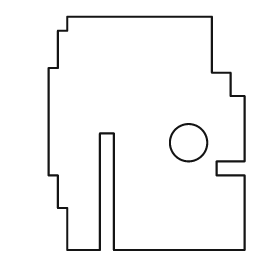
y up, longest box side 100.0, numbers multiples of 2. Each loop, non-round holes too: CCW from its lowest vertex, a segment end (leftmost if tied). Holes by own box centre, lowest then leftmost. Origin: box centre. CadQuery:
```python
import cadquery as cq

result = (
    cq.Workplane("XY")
    .moveTo(-34.0, -50.0)
    .lineTo(-20.0, -50.0)
    .lineTo(-20.0, 0.0)
    .lineTo(-14.0, 0.0)
    .lineTo(-14.0, -50.0)
    .lineTo(42.0, -50.0)
    .lineTo(42.0, -18.0)
    .lineTo(30.0, -18.0)
    .lineTo(30.0, -12.0)
    .lineTo(42.0, -12.0)
    .lineTo(42.0, 16.0)
    .lineTo(36.0, 16.0)
    .lineTo(36.0, 26.0)
    .lineTo(28.0, 26.0)
    .lineTo(28.0, 50.0)
    .lineTo(-34.0, 50.0)
    .lineTo(-34.0, 44.0)
    .lineTo(-38.0, 44.0)
    .lineTo(-38.0, 28.0)
    .lineTo(-42.0, 28.0)
    .lineTo(-42.0, -18.0)
    .lineTo(-38.0, -18.0)
    .lineTo(-38.0, -32.0)
    .lineTo(-34.0, -32.0)
    .close()
    .moveTo(18.0, -4.0)
    .circle(8.0)
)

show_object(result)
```